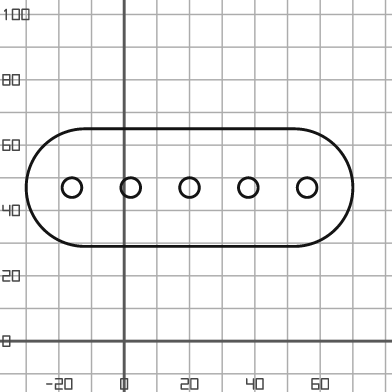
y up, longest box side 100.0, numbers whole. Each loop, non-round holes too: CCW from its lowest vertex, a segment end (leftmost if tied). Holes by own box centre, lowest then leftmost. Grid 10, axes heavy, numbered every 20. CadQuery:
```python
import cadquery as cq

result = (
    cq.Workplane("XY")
    .moveTo(-12.0, 29.0)
    .lineTo(52.0, 29.0)
    .threePointArc((70.0, 47.0), (52.0, 65.0))
    .lineTo(-12.0, 65.0)
    .threePointArc((-30.0, 47.0), (-12.0, 29.0))
    .close()
    .moveTo(-16.0, 47.0)
    .circle(3.0)
    .moveTo(2.0, 47.0)
    .circle(3.0)
    .moveTo(20.0, 47.0)
    .circle(3.0)
    .moveTo(38.0, 47.0)
    .circle(3.0)
    .moveTo(56.0, 47.0)
    .circle(3.0)
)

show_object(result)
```